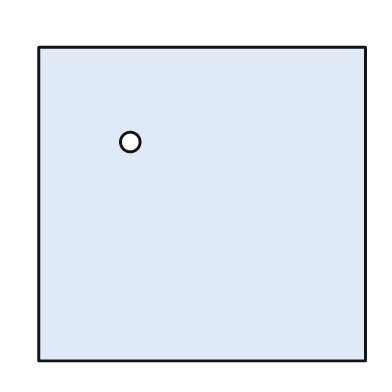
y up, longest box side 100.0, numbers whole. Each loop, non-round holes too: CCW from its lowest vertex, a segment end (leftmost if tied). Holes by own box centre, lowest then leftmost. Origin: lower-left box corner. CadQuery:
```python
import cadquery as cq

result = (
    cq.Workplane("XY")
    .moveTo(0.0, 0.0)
    .lineTo(100.0, 0.0)
    .lineTo(100.0, 96.0)
    .lineTo(0.0, 96.0)
    .close()
    .moveTo(28.0, 67.0)
    .circle(3.0)
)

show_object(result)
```